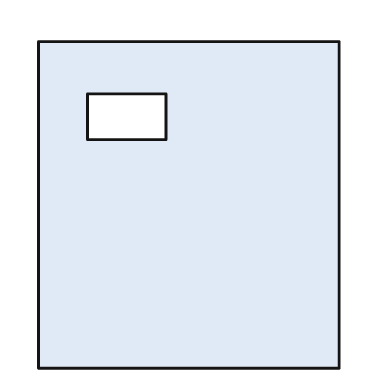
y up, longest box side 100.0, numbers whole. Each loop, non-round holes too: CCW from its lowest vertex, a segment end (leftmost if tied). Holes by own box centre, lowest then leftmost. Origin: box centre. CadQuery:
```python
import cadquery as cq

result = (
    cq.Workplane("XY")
    .moveTo(-46.0, -50.0)
    .lineTo(46.0, -50.0)
    .lineTo(46.0, 50.0)
    .lineTo(-46.0, 50.0)
    .close()
    .moveTo(-31.0, 20.0)
    .lineTo(-7.0, 20.0)
    .lineTo(-7.0, 34.0)
    .lineTo(-31.0, 34.0)
    .close()
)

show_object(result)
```